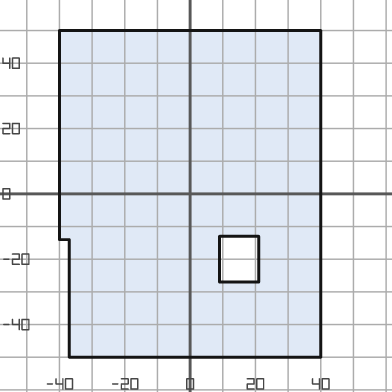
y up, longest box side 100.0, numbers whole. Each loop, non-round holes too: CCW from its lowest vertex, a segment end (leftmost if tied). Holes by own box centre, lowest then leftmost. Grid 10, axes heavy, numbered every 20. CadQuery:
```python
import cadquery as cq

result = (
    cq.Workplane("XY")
    .moveTo(-37.0, -50.0)
    .lineTo(40.0, -50.0)
    .lineTo(40.0, 50.0)
    .lineTo(-40.0, 50.0)
    .lineTo(-40.0, -14.0)
    .lineTo(-37.0, -14.0)
    .close()
    .moveTo(9.0, -27.0)
    .lineTo(21.0, -27.0)
    .lineTo(21.0, -13.0)
    .lineTo(9.0, -13.0)
    .close()
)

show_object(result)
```